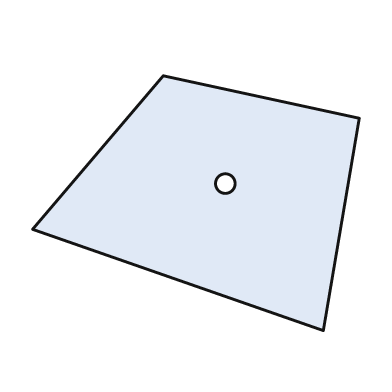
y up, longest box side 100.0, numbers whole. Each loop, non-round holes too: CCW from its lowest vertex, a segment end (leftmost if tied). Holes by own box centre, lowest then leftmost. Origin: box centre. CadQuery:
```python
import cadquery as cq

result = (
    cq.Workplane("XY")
    .moveTo(39.0, -39.0)
    .lineTo(50.0, 26.0)
    .lineTo(-10.0, 39.0)
    .lineTo(-50.0, -8.0)
    .close()
    .moveTo(9.0, 6.0)
    .circle(3.0)
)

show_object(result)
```